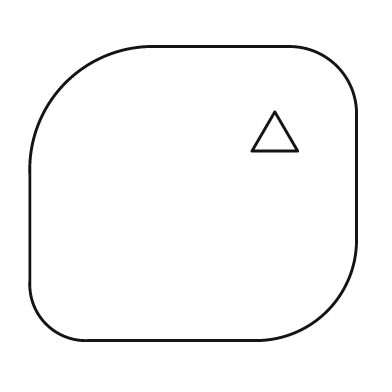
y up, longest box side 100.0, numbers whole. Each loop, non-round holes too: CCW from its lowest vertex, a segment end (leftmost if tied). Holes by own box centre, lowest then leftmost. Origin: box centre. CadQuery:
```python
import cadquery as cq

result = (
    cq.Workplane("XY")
    .moveTo(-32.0, -45.0)
    .lineTo(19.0, -45.0)
    .threePointArc((41.0, -36.0), (50.0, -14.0))
    .lineTo(50.0, 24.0)
    .threePointArc((44.0, 39.0), (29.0, 45.0))
    .lineTo(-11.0, 45.0)
    .threePointArc((-39.0, 34.0), (-50.0, 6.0))
    .lineTo(-50.0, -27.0)
    .threePointArc((-45.0, -40.0), (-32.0, -45.0))
    .close()
    .moveTo(18.0, 13.0)
    .lineTo(32.0, 13.0)
    .lineTo(25.0, 25.0)
    .close()
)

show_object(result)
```